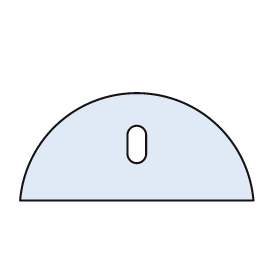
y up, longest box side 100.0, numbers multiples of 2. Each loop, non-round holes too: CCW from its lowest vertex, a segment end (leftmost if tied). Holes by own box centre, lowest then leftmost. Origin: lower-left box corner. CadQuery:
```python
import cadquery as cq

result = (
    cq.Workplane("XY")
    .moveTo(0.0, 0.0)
    .lineTo(100.0, 0.0)
    .threePointArc((50.0, 46.0), (0.0, 0.0))
    .close()
    .moveTo(46.0, 20.0)
    .threePointArc((50.0, 16.0), (54.0, 20.0))
    .lineTo(54.0, 28.0)
    .threePointArc((50.0, 32.0), (46.0, 28.0))
    .close()
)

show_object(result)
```